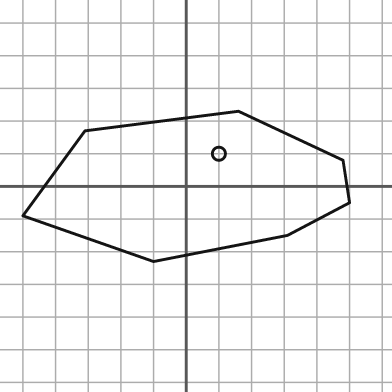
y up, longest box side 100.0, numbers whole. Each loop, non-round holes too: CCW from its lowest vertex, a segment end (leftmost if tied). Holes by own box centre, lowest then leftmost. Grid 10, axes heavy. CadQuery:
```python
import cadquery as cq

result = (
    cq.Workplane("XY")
    .moveTo(-10.0, -23.0)
    .lineTo(31.0, -15.0)
    .lineTo(50.0, -5.0)
    .lineTo(48.0, 8.0)
    .lineTo(16.0, 23.0)
    .lineTo(-31.0, 17.0)
    .lineTo(-50.0, -9.0)
    .close()
    .moveTo(10.0, 10.0)
    .circle(2.0)
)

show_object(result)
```